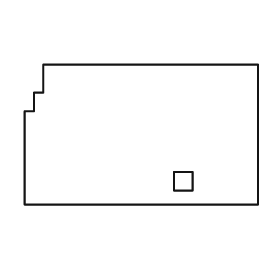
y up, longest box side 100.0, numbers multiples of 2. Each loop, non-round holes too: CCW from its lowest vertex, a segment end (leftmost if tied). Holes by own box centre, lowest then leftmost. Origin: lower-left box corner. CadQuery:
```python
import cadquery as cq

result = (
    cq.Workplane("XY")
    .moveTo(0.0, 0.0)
    .lineTo(100.0, 0.0)
    .lineTo(100.0, 60.0)
    .lineTo(8.0, 60.0)
    .lineTo(8.0, 48.0)
    .lineTo(4.0, 48.0)
    .lineTo(4.0, 40.0)
    .lineTo(0.0, 40.0)
    .close()
    .moveTo(64.0, 6.0)
    .lineTo(72.0, 6.0)
    .lineTo(72.0, 14.0)
    .lineTo(64.0, 14.0)
    .close()
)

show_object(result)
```